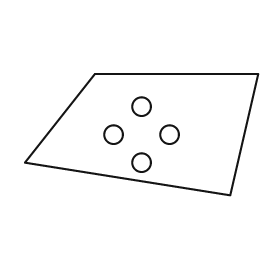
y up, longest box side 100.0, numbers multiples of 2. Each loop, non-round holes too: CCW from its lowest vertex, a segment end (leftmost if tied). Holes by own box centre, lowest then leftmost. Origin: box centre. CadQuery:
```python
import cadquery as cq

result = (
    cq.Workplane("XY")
    .moveTo(38.0, -26.0)
    .lineTo(50.0, 26.0)
    .lineTo(-20.0, 26.0)
    .lineTo(-50.0, -12.0)
    .close()
    .moveTo(0.0, -12.0)
    .circle(4.0)
    .moveTo(-12.0, 0.0)
    .circle(4.0)
    .moveTo(12.0, 0.0)
    .circle(4.0)
    .moveTo(0.0, 12.0)
    .circle(4.0)
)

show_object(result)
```